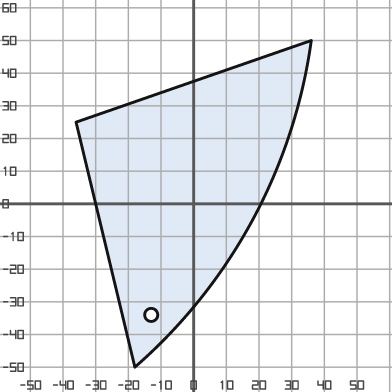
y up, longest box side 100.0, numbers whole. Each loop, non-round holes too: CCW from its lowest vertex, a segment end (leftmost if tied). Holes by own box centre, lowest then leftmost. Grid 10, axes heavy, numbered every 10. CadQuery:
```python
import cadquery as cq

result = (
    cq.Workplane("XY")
    .moveTo(-18.0, -50.0)
    .threePointArc((18.0, -5.0), (36.0, 50.0))
    .lineTo(-36.0, 25.0)
    .close()
    .moveTo(-13.0, -34.0)
    .circle(2.0)
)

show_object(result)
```